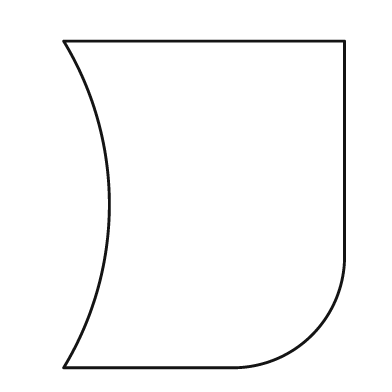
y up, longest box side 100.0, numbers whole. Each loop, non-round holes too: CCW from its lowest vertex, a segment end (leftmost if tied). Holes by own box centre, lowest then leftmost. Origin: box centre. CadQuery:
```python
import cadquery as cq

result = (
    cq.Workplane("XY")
    .moveTo(-43.0, -50.0)
    .lineTo(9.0, -50.0)
    .threePointArc((33.0, -40.0), (43.0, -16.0))
    .lineTo(43.0, 50.0)
    .lineTo(-43.0, 50.0)
    .threePointArc((-29.0, 0.0), (-43.0, -50.0))
    .close()
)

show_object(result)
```